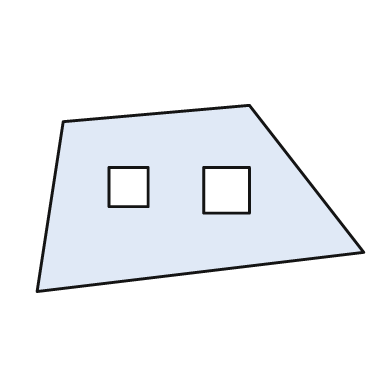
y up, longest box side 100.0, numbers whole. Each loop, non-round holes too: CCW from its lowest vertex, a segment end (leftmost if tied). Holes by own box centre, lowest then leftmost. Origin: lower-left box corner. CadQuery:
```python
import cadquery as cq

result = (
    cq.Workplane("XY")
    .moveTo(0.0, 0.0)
    .lineTo(100.0, 12.0)
    .lineTo(65.0, 57.0)
    .lineTo(8.0, 52.0)
    .close()
    .moveTo(51.0, 24.0)
    .lineTo(65.0, 24.0)
    .lineTo(65.0, 38.0)
    .lineTo(51.0, 38.0)
    .close()
    .moveTo(22.0, 26.0)
    .lineTo(34.0, 26.0)
    .lineTo(34.0, 38.0)
    .lineTo(22.0, 38.0)
    .close()
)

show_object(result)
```